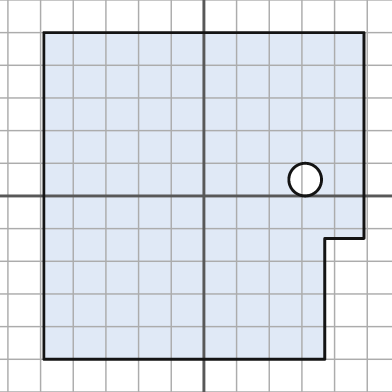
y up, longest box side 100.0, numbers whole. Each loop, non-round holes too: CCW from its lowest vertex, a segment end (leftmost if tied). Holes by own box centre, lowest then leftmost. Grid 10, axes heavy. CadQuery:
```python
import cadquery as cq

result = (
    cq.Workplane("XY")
    .moveTo(-49.0, -50.0)
    .lineTo(37.0, -50.0)
    .lineTo(37.0, -13.0)
    .lineTo(49.0, -13.0)
    .lineTo(49.0, 50.0)
    .lineTo(-49.0, 50.0)
    .close()
    .moveTo(31.0, 5.0)
    .circle(5.0)
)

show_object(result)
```